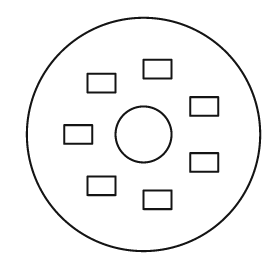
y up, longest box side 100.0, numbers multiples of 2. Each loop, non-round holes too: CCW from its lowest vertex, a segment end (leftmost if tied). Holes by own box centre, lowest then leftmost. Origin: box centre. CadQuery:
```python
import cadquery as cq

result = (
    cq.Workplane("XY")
    .moveTo(0.0, 0.0)
    .circle(50.0)
    .moveTo(0.0, -32.0)
    .lineTo(12.0, -32.0)
    .lineTo(12.0, -24.0)
    .lineTo(0.0, -24.0)
    .close()
    .moveTo(-24.0, -26.0)
    .lineTo(-12.0, -26.0)
    .lineTo(-12.0, -18.0)
    .lineTo(-24.0, -18.0)
    .close()
    .moveTo(20.0, -16.0)
    .lineTo(32.0, -16.0)
    .lineTo(32.0, -8.0)
    .lineTo(20.0, -8.0)
    .close()
    .moveTo(-34.0, -4.0)
    .lineTo(-22.0, -4.0)
    .lineTo(-22.0, 4.0)
    .lineTo(-34.0, 4.0)
    .close()
    .moveTo(0.0, 0.0)
    .circle(12.0)
    .moveTo(20.0, 8.0)
    .lineTo(32.0, 8.0)
    .lineTo(32.0, 16.0)
    .lineTo(20.0, 16.0)
    .close()
    .moveTo(-24.0, 18.0)
    .lineTo(-12.0, 18.0)
    .lineTo(-12.0, 26.0)
    .lineTo(-24.0, 26.0)
    .close()
    .moveTo(0.0, 24.0)
    .lineTo(12.0, 24.0)
    .lineTo(12.0, 32.0)
    .lineTo(0.0, 32.0)
    .close()
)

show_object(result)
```